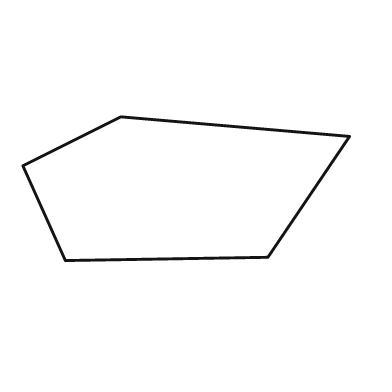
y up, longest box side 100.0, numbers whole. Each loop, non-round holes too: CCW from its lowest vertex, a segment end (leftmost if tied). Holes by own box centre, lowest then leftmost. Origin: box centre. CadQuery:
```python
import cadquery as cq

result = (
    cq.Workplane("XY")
    .moveTo(-37.0, -22.0)
    .lineTo(25.0, -21.0)
    .lineTo(50.0, 16.0)
    .lineTo(-20.0, 22.0)
    .lineTo(-50.0, 7.0)
    .close()
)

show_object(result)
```